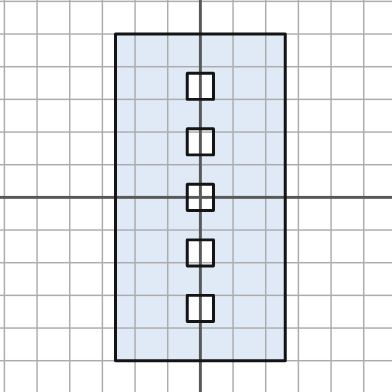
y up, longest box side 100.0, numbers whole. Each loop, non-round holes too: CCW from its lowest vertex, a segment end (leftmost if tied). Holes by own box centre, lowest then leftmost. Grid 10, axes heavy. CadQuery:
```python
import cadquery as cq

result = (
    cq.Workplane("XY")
    .moveTo(-26.0, -50.0)
    .lineTo(26.0, -50.0)
    .lineTo(26.0, 50.0)
    .lineTo(-26.0, 50.0)
    .close()
    .moveTo(-4.0, -38.0)
    .lineTo(4.0, -38.0)
    .lineTo(4.0, -30.0)
    .lineTo(-4.0, -30.0)
    .close()
    .moveTo(-4.0, -21.0)
    .lineTo(4.0, -21.0)
    .lineTo(4.0, -13.0)
    .lineTo(-4.0, -13.0)
    .close()
    .moveTo(-4.0, -4.0)
    .lineTo(4.0, -4.0)
    .lineTo(4.0, 4.0)
    .lineTo(-4.0, 4.0)
    .close()
    .moveTo(-4.0, 13.0)
    .lineTo(4.0, 13.0)
    .lineTo(4.0, 21.0)
    .lineTo(-4.0, 21.0)
    .close()
    .moveTo(-4.0, 30.0)
    .lineTo(4.0, 30.0)
    .lineTo(4.0, 38.0)
    .lineTo(-4.0, 38.0)
    .close()
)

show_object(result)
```